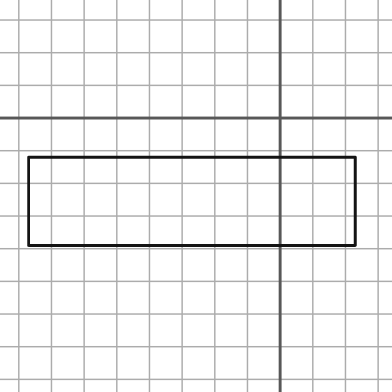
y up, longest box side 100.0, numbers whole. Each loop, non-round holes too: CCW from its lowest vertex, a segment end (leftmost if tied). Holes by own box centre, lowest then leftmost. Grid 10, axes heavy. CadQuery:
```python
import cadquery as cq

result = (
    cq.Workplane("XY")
    .moveTo(-77.0, -39.0)
    .lineTo(23.0, -39.0)
    .lineTo(23.0, -12.0)
    .lineTo(-77.0, -12.0)
    .close()
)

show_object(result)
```